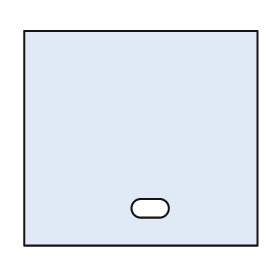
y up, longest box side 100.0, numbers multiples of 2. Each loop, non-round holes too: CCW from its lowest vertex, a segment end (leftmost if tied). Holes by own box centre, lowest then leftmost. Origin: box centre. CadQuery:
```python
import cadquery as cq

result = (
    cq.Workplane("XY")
    .moveTo(-50.0, -46.0)
    .lineTo(50.0, -46.0)
    .lineTo(50.0, 46.0)
    .lineTo(-50.0, 46.0)
    .close()
    .moveTo(0.0, -34.0)
    .lineTo(8.0, -34.0)
    .threePointArc((12.0, -30.0), (8.0, -26.0))
    .lineTo(0.0, -26.0)
    .threePointArc((-4.0, -30.0), (0.0, -34.0))
    .close()
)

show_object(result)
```